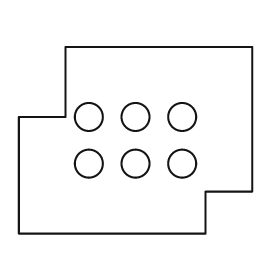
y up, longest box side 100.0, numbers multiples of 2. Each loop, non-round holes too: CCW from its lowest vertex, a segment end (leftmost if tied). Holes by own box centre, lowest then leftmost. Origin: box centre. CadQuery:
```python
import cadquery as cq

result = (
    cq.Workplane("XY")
    .moveTo(-50.0, -40.0)
    .lineTo(30.0, -40.0)
    .lineTo(30.0, -22.0)
    .lineTo(50.0, -22.0)
    .lineTo(50.0, 40.0)
    .lineTo(-30.0, 40.0)
    .lineTo(-30.0, 10.0)
    .lineTo(-50.0, 10.0)
    .close()
    .moveTo(-20.0, -10.0)
    .circle(6.0)
    .moveTo(0.0, -10.0)
    .circle(6.0)
    .moveTo(20.0, -10.0)
    .circle(6.0)
    .moveTo(-20.0, 10.0)
    .circle(6.0)
    .moveTo(0.0, 10.0)
    .circle(6.0)
    .moveTo(20.0, 10.0)
    .circle(6.0)
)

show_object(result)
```